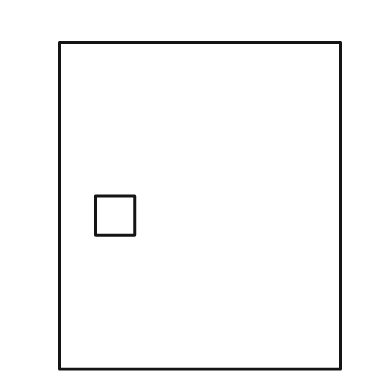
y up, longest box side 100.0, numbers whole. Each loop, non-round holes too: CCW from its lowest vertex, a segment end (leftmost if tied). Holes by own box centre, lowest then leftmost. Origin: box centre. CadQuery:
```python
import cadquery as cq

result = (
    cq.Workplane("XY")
    .moveTo(-43.0, -50.0)
    .lineTo(43.0, -50.0)
    .lineTo(43.0, 50.0)
    .lineTo(-43.0, 50.0)
    .close()
    .moveTo(-32.0, -9.0)
    .lineTo(-20.0, -9.0)
    .lineTo(-20.0, 3.0)
    .lineTo(-32.0, 3.0)
    .close()
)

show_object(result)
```